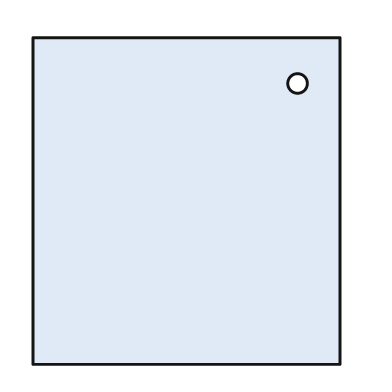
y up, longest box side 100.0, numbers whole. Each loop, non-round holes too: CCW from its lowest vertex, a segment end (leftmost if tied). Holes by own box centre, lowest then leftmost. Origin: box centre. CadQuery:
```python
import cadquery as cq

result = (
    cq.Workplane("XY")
    .moveTo(-47.0, -50.0)
    .lineTo(47.0, -50.0)
    .lineTo(47.0, 50.0)
    .lineTo(-47.0, 50.0)
    .close()
    .moveTo(34.0, 36.0)
    .circle(3.0)
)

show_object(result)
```